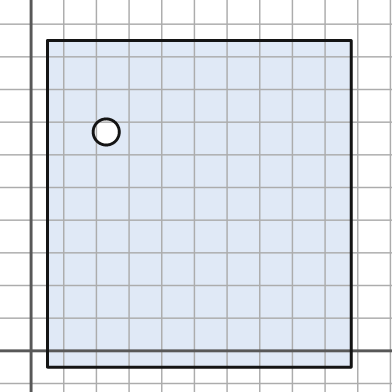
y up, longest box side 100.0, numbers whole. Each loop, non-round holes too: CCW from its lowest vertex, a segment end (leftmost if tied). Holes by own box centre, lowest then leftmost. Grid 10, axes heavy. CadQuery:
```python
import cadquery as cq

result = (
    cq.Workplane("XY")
    .moveTo(5.0, -5.0)
    .lineTo(98.0, -5.0)
    .lineTo(98.0, 95.0)
    .lineTo(5.0, 95.0)
    .close()
    .moveTo(23.0, 67.0)
    .circle(4.0)
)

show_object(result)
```